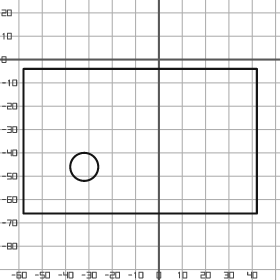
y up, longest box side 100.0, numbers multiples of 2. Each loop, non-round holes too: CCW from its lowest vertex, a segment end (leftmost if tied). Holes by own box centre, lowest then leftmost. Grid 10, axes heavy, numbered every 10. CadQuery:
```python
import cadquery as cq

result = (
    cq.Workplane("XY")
    .moveTo(-58.0, -66.0)
    .lineTo(42.0, -66.0)
    .lineTo(42.0, -4.0)
    .lineTo(-58.0, -4.0)
    .close()
    .moveTo(-32.0, -46.0)
    .circle(6.0)
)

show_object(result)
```